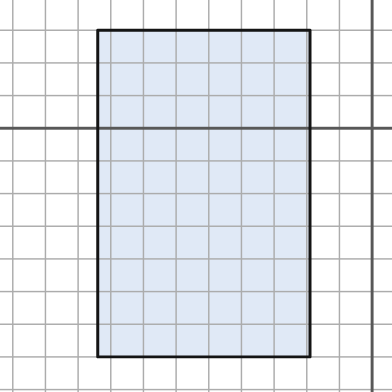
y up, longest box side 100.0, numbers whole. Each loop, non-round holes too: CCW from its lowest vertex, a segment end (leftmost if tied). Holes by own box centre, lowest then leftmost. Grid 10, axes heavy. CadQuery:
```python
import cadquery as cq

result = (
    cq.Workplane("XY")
    .moveTo(-84.0, -70.0)
    .lineTo(-19.0, -70.0)
    .lineTo(-19.0, 30.0)
    .lineTo(-84.0, 30.0)
    .close()
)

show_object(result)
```